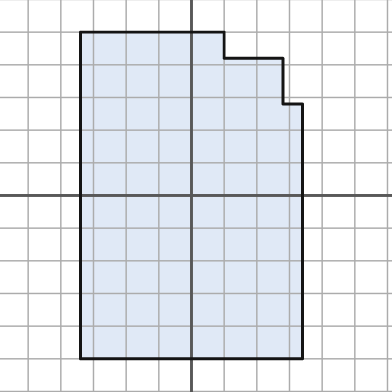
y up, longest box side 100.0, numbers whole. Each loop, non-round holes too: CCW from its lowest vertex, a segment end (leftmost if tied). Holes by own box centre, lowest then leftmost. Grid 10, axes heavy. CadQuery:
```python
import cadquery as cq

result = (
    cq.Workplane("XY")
    .moveTo(-34.0, -50.0)
    .lineTo(34.0, -50.0)
    .lineTo(34.0, 28.0)
    .lineTo(28.0, 28.0)
    .lineTo(28.0, 42.0)
    .lineTo(10.0, 42.0)
    .lineTo(10.0, 50.0)
    .lineTo(-34.0, 50.0)
    .close()
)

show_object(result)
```